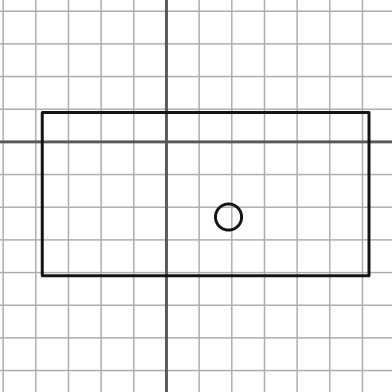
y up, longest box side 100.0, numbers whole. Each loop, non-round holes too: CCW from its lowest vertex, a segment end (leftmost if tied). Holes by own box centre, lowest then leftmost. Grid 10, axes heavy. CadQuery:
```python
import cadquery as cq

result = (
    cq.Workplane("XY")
    .moveTo(-38.0, -41.0)
    .lineTo(62.0, -41.0)
    .lineTo(62.0, 9.0)
    .lineTo(-38.0, 9.0)
    .close()
    .moveTo(19.0, -23.0)
    .circle(4.0)
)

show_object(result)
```